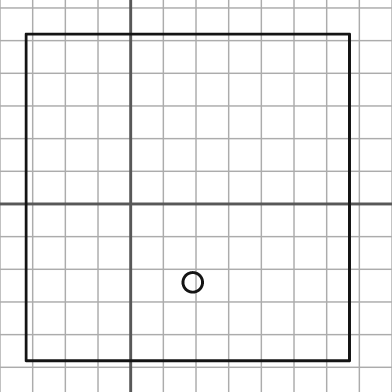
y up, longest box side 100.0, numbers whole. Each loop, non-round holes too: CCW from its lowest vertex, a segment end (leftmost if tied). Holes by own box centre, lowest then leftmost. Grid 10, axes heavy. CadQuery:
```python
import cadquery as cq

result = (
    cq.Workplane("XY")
    .moveTo(-32.0, -48.0)
    .lineTo(67.0, -48.0)
    .lineTo(67.0, 52.0)
    .lineTo(-32.0, 52.0)
    .close()
    .moveTo(19.0, -24.0)
    .circle(3.0)
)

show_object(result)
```